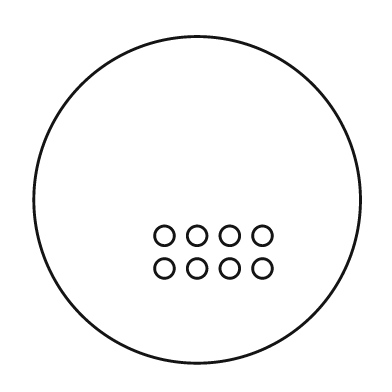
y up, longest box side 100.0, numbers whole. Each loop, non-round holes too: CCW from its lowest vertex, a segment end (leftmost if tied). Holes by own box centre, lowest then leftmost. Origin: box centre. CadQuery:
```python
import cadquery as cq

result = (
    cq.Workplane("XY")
    .moveTo(0.0, 0.0)
    .circle(50.0)
    .moveTo(-10.0, -21.0)
    .circle(3.0)
    .moveTo(0.0, -21.0)
    .circle(3.0)
    .moveTo(10.0, -21.0)
    .circle(3.0)
    .moveTo(20.0, -21.0)
    .circle(3.0)
    .moveTo(-10.0, -11.0)
    .circle(3.0)
    .moveTo(0.0, -11.0)
    .circle(3.0)
    .moveTo(10.0, -11.0)
    .circle(3.0)
    .moveTo(20.0, -11.0)
    .circle(3.0)
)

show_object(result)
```